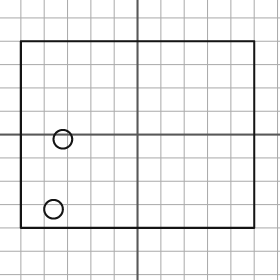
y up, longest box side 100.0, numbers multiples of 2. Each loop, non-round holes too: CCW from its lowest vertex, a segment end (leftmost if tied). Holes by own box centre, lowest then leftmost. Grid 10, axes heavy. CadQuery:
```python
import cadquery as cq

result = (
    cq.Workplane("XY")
    .moveTo(-50.0, -40.0)
    .lineTo(50.0, -40.0)
    .lineTo(50.0, 40.0)
    .lineTo(-50.0, 40.0)
    .close()
    .moveTo(-36.0, -32.0)
    .circle(4.0)
    .moveTo(-32.0, -2.0)
    .circle(4.0)
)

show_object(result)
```